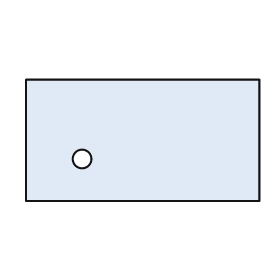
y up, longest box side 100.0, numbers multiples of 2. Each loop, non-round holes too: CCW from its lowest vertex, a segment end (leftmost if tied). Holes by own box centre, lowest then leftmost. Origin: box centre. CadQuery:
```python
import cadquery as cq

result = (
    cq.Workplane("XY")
    .moveTo(-50.0, -26.0)
    .lineTo(50.0, -26.0)
    .lineTo(50.0, 26.0)
    .lineTo(-50.0, 26.0)
    .close()
    .moveTo(-26.0, -8.0)
    .circle(4.0)
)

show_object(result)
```